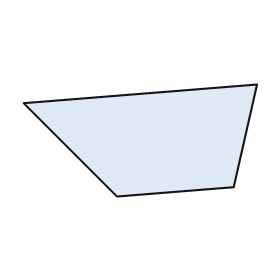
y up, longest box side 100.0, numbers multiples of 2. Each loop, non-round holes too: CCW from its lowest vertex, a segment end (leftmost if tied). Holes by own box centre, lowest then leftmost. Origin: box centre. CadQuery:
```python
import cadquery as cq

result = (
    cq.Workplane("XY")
    .moveTo(-10.0, -24.0)
    .lineTo(40.0, -20.0)
    .lineTo(50.0, 24.0)
    .lineTo(-50.0, 16.0)
    .close()
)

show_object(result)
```